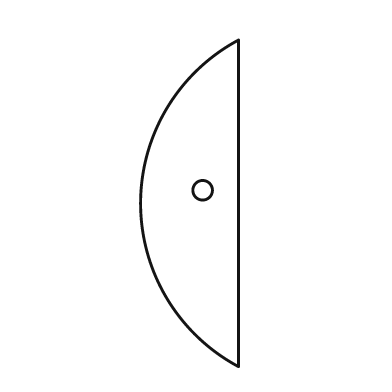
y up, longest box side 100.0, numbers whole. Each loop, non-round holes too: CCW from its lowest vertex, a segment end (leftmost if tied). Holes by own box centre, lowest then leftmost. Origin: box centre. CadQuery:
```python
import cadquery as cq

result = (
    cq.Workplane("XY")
    .moveTo(15.0, -50.0)
    .lineTo(15.0, 50.0)
    .threePointArc((-15.0, 0.0), (15.0, -50.0))
    .close()
    .moveTo(4.0, 4.0)
    .circle(3.0)
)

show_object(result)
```